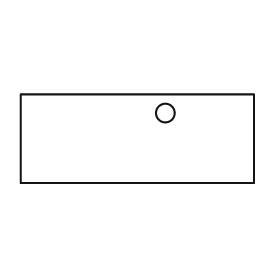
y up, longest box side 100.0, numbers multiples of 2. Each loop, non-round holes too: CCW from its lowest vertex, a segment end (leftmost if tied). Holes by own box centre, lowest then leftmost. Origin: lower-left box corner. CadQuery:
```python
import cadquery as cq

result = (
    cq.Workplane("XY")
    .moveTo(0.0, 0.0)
    .lineTo(100.0, 0.0)
    .lineTo(100.0, 38.0)
    .lineTo(0.0, 38.0)
    .close()
    .moveTo(62.0, 30.0)
    .circle(4.0)
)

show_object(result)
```